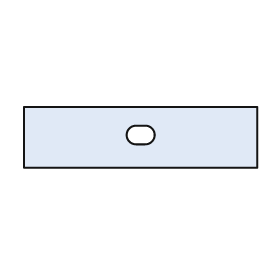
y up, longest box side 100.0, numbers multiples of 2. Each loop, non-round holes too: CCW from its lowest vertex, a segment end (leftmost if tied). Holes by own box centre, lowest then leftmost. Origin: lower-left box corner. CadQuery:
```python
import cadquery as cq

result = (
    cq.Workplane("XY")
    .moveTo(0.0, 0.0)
    .lineTo(100.0, 0.0)
    .lineTo(100.0, 26.0)
    .lineTo(0.0, 26.0)
    .close()
    .moveTo(48.0, 10.0)
    .lineTo(52.0, 10.0)
    .threePointArc((56.0, 14.0), (52.0, 18.0))
    .lineTo(48.0, 18.0)
    .threePointArc((44.0, 14.0), (48.0, 10.0))
    .close()
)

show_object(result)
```